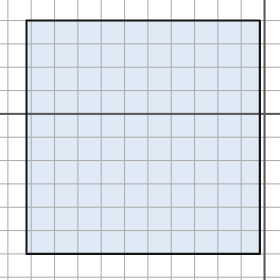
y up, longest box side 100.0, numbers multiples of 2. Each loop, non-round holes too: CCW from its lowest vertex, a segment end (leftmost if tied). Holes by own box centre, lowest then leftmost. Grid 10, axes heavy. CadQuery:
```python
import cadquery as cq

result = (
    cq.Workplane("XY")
    .moveTo(-102.0, -60.0)
    .lineTo(-2.0, -60.0)
    .lineTo(-2.0, 40.0)
    .lineTo(-102.0, 40.0)
    .close()
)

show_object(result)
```